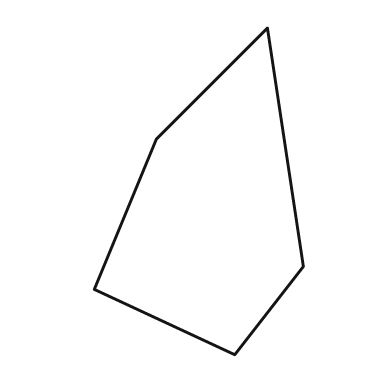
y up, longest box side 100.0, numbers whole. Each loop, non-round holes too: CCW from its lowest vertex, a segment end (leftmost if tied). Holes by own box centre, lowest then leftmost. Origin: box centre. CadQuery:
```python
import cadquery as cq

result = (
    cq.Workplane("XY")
    .moveTo(11.0, -50.0)
    .lineTo(32.0, -23.0)
    .lineTo(21.0, 50.0)
    .lineTo(-13.0, 16.0)
    .lineTo(-32.0, -30.0)
    .close()
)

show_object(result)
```